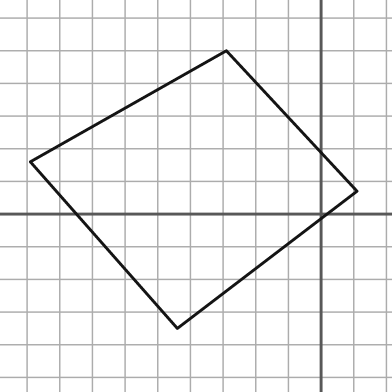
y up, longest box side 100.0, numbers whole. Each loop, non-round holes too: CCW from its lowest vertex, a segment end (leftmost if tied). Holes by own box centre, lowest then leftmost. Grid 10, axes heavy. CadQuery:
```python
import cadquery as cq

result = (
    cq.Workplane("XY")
    .moveTo(-44.0, -35.0)
    .lineTo(11.0, 7.0)
    .lineTo(-29.0, 50.0)
    .lineTo(-89.0, 16.0)
    .close()
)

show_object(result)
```